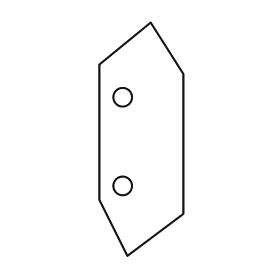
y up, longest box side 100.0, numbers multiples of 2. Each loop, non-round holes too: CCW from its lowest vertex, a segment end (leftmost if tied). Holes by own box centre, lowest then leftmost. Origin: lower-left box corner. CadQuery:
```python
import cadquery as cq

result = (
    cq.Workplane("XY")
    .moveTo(12.0, 0.0)
    .lineTo(36.0, 18.0)
    .lineTo(36.0, 78.0)
    .lineTo(22.0, 100.0)
    .lineTo(0.0, 82.0)
    .lineTo(0.0, 24.0)
    .close()
    .moveTo(10.0, 30.0)
    .circle(4.0)
    .moveTo(10.0, 68.0)
    .circle(4.0)
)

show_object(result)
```